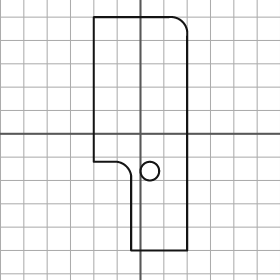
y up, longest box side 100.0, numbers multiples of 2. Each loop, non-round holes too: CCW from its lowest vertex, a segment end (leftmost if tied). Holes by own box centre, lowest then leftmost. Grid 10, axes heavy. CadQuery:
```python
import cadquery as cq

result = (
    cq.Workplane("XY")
    .moveTo(-4.0, -50.0)
    .lineTo(20.0, -50.0)
    .lineTo(20.0, 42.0)
    .threePointArc((18.0, 48.0), (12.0, 50.0))
    .lineTo(-20.0, 50.0)
    .lineTo(-20.0, -12.0)
    .lineTo(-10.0, -12.0)
    .threePointArc((-6.0, -14.0), (-4.0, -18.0))
    .close()
    .moveTo(4.0, -16.0)
    .circle(4.0)
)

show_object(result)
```